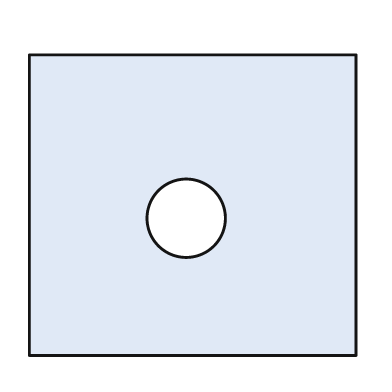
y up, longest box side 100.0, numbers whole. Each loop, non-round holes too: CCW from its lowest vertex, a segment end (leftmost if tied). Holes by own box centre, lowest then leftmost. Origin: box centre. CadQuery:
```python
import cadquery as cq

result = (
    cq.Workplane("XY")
    .moveTo(-50.0, -46.0)
    .lineTo(50.0, -46.0)
    .lineTo(50.0, 46.0)
    .lineTo(-50.0, 46.0)
    .close()
    .moveTo(-2.0, -4.0)
    .circle(12.0)
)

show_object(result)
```